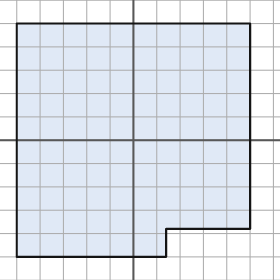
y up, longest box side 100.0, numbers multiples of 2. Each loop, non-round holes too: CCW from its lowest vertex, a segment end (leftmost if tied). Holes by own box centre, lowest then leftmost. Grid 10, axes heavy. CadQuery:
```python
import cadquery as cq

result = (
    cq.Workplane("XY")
    .moveTo(-50.0, -50.0)
    .lineTo(14.0, -50.0)
    .lineTo(14.0, -38.0)
    .lineTo(50.0, -38.0)
    .lineTo(50.0, 50.0)
    .lineTo(-50.0, 50.0)
    .close()
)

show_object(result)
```